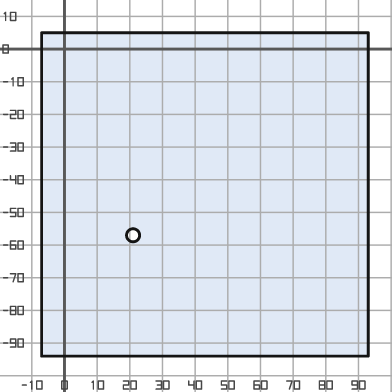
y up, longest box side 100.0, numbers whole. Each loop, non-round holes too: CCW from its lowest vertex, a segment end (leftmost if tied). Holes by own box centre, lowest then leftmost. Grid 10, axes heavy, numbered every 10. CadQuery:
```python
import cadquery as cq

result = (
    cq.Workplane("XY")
    .moveTo(-7.0, -94.0)
    .lineTo(93.0, -94.0)
    .lineTo(93.0, 5.0)
    .lineTo(-7.0, 5.0)
    .close()
    .moveTo(21.0, -57.0)
    .circle(2.0)
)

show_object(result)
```